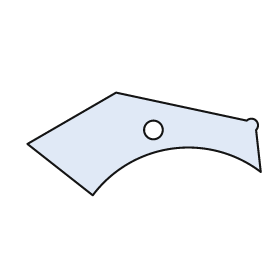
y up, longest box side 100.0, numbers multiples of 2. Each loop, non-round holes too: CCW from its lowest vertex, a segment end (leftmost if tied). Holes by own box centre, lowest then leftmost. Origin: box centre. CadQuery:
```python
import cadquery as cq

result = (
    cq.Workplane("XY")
    .moveTo(-22.0, -22.0)
    .threePointArc((12.0, -2.0), (50.0, -12.0))
    .lineTo(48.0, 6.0)
    .threePointArc((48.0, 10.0), (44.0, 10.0))
    .lineTo(-12.0, 22.0)
    .lineTo(-50.0, 0.0)
    .close()
    .moveTo(4.0, 6.0)
    .circle(4.0)
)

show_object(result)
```